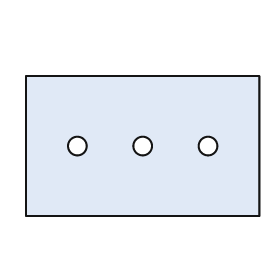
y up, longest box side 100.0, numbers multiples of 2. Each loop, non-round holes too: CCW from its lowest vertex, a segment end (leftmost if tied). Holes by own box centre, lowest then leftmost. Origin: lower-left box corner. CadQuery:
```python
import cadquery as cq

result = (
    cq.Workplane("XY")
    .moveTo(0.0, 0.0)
    .lineTo(100.0, 0.0)
    .lineTo(100.0, 60.0)
    .lineTo(0.0, 60.0)
    .close()
    .moveTo(22.0, 30.0)
    .circle(4.0)
    .moveTo(50.0, 30.0)
    .circle(4.0)
    .moveTo(78.0, 30.0)
    .circle(4.0)
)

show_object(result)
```